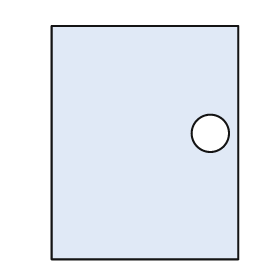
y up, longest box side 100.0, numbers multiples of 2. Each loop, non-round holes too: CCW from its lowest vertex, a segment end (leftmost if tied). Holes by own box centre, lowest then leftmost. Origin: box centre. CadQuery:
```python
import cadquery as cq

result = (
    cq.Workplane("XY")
    .moveTo(-40.0, -50.0)
    .lineTo(40.0, -50.0)
    .lineTo(40.0, 50.0)
    .lineTo(-40.0, 50.0)
    .close()
    .moveTo(28.0, 4.0)
    .circle(8.0)
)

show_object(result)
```